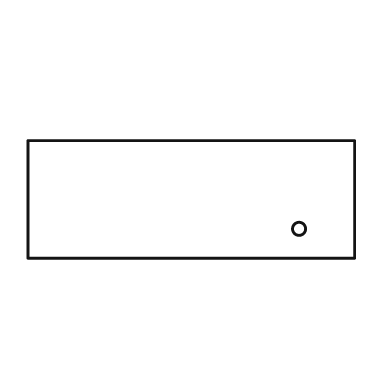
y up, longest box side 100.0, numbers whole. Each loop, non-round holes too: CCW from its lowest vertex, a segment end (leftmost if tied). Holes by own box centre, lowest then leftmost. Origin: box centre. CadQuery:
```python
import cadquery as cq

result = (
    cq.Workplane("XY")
    .moveTo(-50.0, -18.0)
    .lineTo(50.0, -18.0)
    .lineTo(50.0, 18.0)
    .lineTo(-50.0, 18.0)
    .close()
    .moveTo(33.0, -9.0)
    .circle(2.0)
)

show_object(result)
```